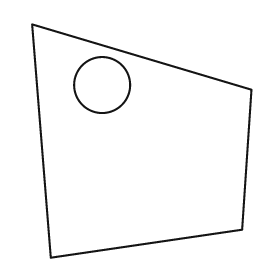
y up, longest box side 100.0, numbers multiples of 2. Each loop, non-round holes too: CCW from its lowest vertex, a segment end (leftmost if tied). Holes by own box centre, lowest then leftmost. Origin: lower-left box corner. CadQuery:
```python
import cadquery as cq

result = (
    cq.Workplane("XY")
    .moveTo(8.0, 0.0)
    .lineTo(90.0, 12.0)
    .lineTo(94.0, 72.0)
    .lineTo(0.0, 100.0)
    .close()
    .moveTo(30.0, 74.0)
    .circle(12.0)
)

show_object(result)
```